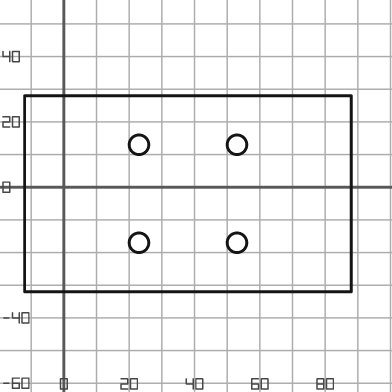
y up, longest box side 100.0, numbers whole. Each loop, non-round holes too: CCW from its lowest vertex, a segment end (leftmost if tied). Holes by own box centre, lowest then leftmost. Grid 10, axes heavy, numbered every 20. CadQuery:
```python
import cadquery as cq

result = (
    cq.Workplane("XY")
    .moveTo(-12.0, -32.0)
    .lineTo(88.0, -32.0)
    .lineTo(88.0, 28.0)
    .lineTo(-12.0, 28.0)
    .close()
    .moveTo(23.0, -17.0)
    .circle(3.0)
    .moveTo(53.0, -17.0)
    .circle(3.0)
    .moveTo(23.0, 13.0)
    .circle(3.0)
    .moveTo(53.0, 13.0)
    .circle(3.0)
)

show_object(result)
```